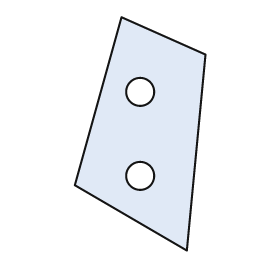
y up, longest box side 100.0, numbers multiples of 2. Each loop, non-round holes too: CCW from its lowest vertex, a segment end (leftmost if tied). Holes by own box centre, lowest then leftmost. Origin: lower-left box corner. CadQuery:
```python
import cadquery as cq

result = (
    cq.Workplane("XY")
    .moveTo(48.0, 0.0)
    .lineTo(56.0, 84.0)
    .lineTo(20.0, 100.0)
    .lineTo(0.0, 28.0)
    .close()
    .moveTo(28.0, 32.0)
    .circle(6.0)
    .moveTo(28.0, 68.0)
    .circle(6.0)
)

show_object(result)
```